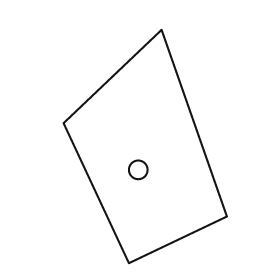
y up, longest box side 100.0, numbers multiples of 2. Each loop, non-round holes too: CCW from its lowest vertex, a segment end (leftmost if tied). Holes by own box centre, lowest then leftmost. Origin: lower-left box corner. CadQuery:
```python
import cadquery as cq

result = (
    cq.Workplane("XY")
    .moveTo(28.0, 0.0)
    .lineTo(70.0, 20.0)
    .lineTo(42.0, 100.0)
    .lineTo(0.0, 60.0)
    .close()
    .moveTo(32.0, 40.0)
    .circle(4.0)
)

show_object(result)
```